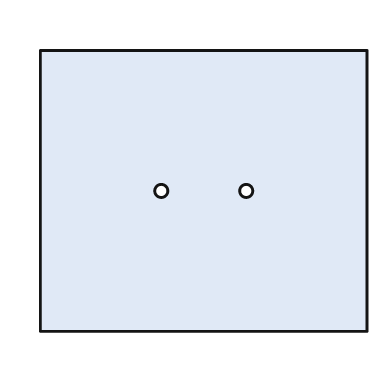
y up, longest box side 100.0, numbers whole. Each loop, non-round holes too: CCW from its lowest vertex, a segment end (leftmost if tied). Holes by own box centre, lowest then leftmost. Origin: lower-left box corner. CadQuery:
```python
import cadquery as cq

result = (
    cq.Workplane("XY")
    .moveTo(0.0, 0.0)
    .lineTo(100.0, 0.0)
    .lineTo(100.0, 86.0)
    .lineTo(0.0, 86.0)
    .close()
    .moveTo(37.0, 43.0)
    .circle(2.0)
    .moveTo(63.0, 43.0)
    .circle(2.0)
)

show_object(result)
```